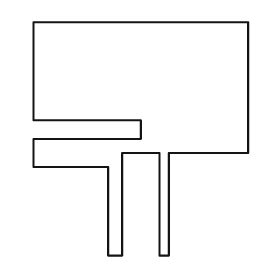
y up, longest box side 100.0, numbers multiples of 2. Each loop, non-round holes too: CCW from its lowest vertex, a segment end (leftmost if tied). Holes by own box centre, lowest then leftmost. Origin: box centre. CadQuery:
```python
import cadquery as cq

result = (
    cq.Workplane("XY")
    .moveTo(-14.0, -50.0)
    .lineTo(-8.0, -50.0)
    .lineTo(-8.0, -6.0)
    .lineTo(8.0, -6.0)
    .lineTo(8.0, -50.0)
    .lineTo(12.0, -50.0)
    .lineTo(12.0, -6.0)
    .lineTo(46.0, -6.0)
    .lineTo(46.0, 50.0)
    .lineTo(-46.0, 50.0)
    .lineTo(-46.0, 8.0)
    .lineTo(0.0, 8.0)
    .lineTo(0.0, 0.0)
    .lineTo(-46.0, 0.0)
    .lineTo(-46.0, -12.0)
    .lineTo(-14.0, -12.0)
    .close()
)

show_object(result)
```